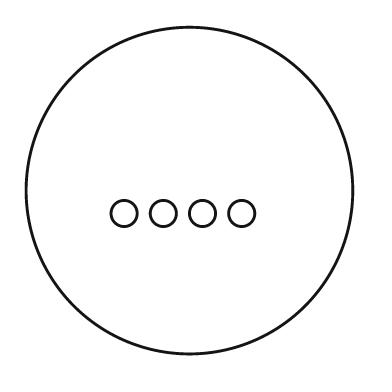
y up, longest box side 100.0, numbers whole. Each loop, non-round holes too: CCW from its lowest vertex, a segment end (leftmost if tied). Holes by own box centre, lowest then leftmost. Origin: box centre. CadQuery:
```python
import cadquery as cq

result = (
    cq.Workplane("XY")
    .moveTo(0.0, 0.0)
    .circle(50.0)
    .moveTo(-20.0, -7.0)
    .circle(4.0)
    .moveTo(-8.0, -7.0)
    .circle(4.0)
    .moveTo(4.0, -7.0)
    .circle(4.0)
    .moveTo(16.0, -7.0)
    .circle(4.0)
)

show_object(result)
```